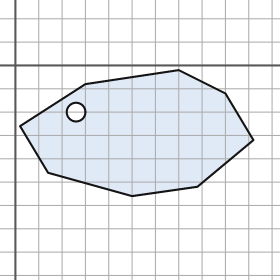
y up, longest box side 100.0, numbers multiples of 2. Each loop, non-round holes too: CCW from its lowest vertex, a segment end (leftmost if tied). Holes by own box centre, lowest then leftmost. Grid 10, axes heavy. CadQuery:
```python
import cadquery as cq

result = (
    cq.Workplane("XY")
    .moveTo(50.0, -56.0)
    .lineTo(78.0, -52.0)
    .lineTo(102.0, -32.0)
    .lineTo(90.0, -12.0)
    .lineTo(70.0, -2.0)
    .lineTo(30.0, -8.0)
    .lineTo(2.0, -26.0)
    .lineTo(14.0, -46.0)
    .close()
    .moveTo(26.0, -20.0)
    .circle(4.0)
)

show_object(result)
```